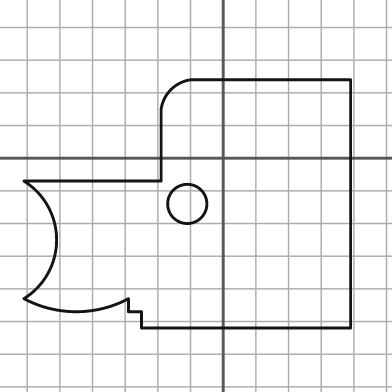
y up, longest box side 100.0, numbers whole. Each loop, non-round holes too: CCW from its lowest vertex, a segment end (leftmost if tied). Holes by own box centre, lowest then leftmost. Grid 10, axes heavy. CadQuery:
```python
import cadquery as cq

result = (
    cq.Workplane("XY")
    .moveTo(-25.0, -52.0)
    .lineTo(39.0, -52.0)
    .lineTo(39.0, 24.0)
    .lineTo(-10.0, 24.0)
    .threePointArc((-16.0, 21.0), (-19.0, 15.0))
    .lineTo(-19.0, -7.0)
    .lineTo(-61.0, -7.0)
    .threePointArc((-51.0, -25.0), (-61.0, -43.0))
    .threePointArc((-45.0, -47.0), (-29.0, -43.0))
    .lineTo(-29.0, -47.0)
    .lineTo(-25.0, -47.0)
    .close()
    .moveTo(-11.0, -14.0)
    .circle(6.0)
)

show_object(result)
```